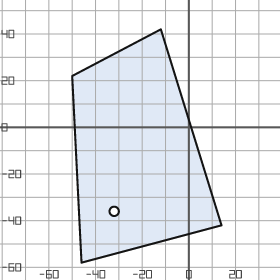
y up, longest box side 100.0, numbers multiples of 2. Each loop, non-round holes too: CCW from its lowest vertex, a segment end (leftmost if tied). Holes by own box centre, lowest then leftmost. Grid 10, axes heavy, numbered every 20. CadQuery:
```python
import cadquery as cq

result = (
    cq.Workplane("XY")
    .moveTo(-46.0, -58.0)
    .lineTo(14.0, -42.0)
    .lineTo(-12.0, 42.0)
    .lineTo(-50.0, 22.0)
    .close()
    .moveTo(-32.0, -36.0)
    .circle(2.0)
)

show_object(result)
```